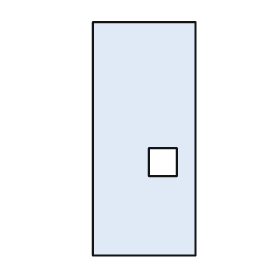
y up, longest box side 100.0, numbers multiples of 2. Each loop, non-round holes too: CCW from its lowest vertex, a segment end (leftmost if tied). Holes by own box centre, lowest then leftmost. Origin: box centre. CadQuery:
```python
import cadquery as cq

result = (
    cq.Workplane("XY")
    .moveTo(-22.0, -50.0)
    .lineTo(22.0, -50.0)
    .lineTo(22.0, 50.0)
    .lineTo(-22.0, 50.0)
    .close()
    .moveTo(2.0, -16.0)
    .lineTo(14.0, -16.0)
    .lineTo(14.0, -4.0)
    .lineTo(2.0, -4.0)
    .close()
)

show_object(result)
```